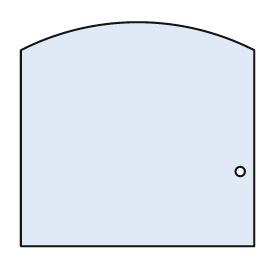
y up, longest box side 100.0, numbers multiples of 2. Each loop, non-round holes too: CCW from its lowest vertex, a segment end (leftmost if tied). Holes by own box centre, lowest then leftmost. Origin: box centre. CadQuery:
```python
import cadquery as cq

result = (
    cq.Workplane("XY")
    .moveTo(-50.0, -48.0)
    .lineTo(50.0, -48.0)
    .lineTo(50.0, 36.0)
    .threePointArc((0.0, 48.0), (-50.0, 36.0))
    .close()
    .moveTo(44.0, -16.0)
    .circle(2.0)
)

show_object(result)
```